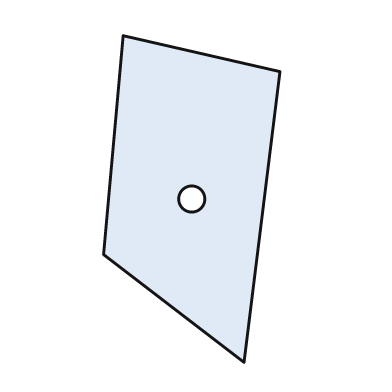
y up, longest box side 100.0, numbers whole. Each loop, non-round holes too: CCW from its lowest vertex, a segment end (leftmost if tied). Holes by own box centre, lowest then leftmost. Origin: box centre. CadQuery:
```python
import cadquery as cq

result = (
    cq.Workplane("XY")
    .moveTo(16.0, -50.0)
    .lineTo(27.0, 39.0)
    .lineTo(-21.0, 50.0)
    .lineTo(-27.0, -17.0)
    .close()
    .moveTo(0.0, 0.0)
    .circle(4.0)
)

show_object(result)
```